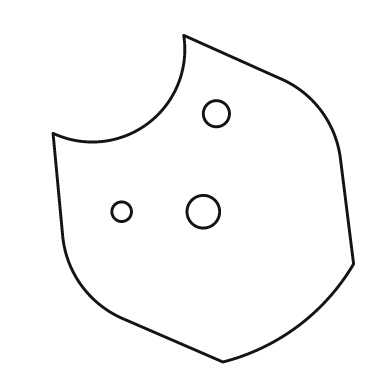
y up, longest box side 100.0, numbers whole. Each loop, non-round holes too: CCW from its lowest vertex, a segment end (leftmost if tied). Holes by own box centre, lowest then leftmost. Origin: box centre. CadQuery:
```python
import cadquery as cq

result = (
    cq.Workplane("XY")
    .moveTo(6.0, -50.0)
    .threePointArc((29.0, -39.0), (46.0, -20.0))
    .lineTo(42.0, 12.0)
    .threePointArc((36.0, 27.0), (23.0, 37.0))
    .lineTo(-6.0, 50.0)
    .threePointArc((-17.0, 23.0), (-46.0, 20.0))
    .lineTo(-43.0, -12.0)
    .threePointArc((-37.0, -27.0), (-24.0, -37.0))
    .close()
    .moveTo(-25.0, -4.0)
    .circle(3.0)
    .moveTo(0.0, -4.0)
    .circle(5.0)
    .moveTo(4.0, 26.0)
    .circle(4.0)
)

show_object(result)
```